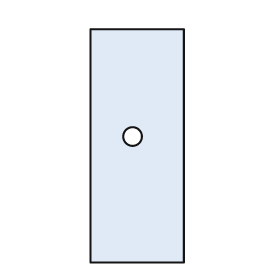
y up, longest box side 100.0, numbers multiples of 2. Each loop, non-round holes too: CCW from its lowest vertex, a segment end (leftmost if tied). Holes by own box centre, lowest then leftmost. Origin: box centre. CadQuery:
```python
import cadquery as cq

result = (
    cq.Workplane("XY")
    .moveTo(-20.0, -50.0)
    .lineTo(20.0, -50.0)
    .lineTo(20.0, 50.0)
    .lineTo(-20.0, 50.0)
    .close()
    .moveTo(-2.0, 4.0)
    .circle(4.0)
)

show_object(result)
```